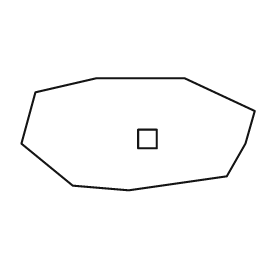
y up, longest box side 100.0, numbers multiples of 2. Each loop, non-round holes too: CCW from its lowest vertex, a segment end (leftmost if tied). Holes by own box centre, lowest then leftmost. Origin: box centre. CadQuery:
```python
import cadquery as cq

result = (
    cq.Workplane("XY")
    .moveTo(-4.0, -24.0)
    .lineTo(38.0, -18.0)
    .lineTo(46.0, -4.0)
    .lineTo(50.0, 10.0)
    .lineTo(20.0, 24.0)
    .lineTo(-18.0, 24.0)
    .lineTo(-44.0, 18.0)
    .lineTo(-50.0, -4.0)
    .lineTo(-28.0, -22.0)
    .close()
    .moveTo(0.0, -6.0)
    .lineTo(8.0, -6.0)
    .lineTo(8.0, 2.0)
    .lineTo(0.0, 2.0)
    .close()
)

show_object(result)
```